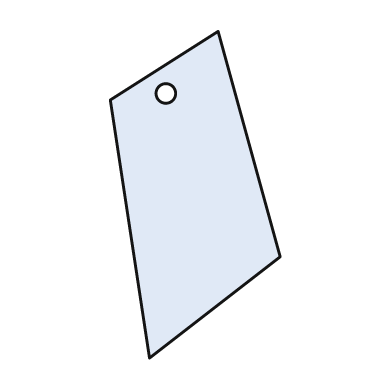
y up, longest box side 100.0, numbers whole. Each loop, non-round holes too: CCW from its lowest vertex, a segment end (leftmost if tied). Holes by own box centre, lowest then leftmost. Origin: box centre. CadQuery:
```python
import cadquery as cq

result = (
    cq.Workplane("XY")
    .moveTo(-14.0, -50.0)
    .lineTo(26.0, -19.0)
    .lineTo(7.0, 50.0)
    .lineTo(-26.0, 29.0)
    .close()
    .moveTo(-9.0, 31.0)
    .circle(3.0)
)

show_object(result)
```